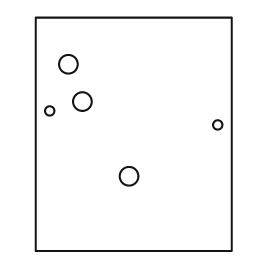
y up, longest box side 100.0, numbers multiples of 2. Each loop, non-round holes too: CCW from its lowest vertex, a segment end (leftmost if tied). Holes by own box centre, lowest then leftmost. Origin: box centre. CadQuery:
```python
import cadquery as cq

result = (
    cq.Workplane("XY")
    .moveTo(-42.0, -50.0)
    .lineTo(42.0, -50.0)
    .lineTo(42.0, 50.0)
    .lineTo(-42.0, 50.0)
    .close()
    .moveTo(-2.0, -18.0)
    .circle(4.0)
    .moveTo(36.0, 4.0)
    .circle(2.0)
    .moveTo(-36.0, 10.0)
    .circle(2.0)
    .moveTo(-22.0, 14.0)
    .circle(4.0)
    .moveTo(-28.0, 30.0)
    .circle(4.0)
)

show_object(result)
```